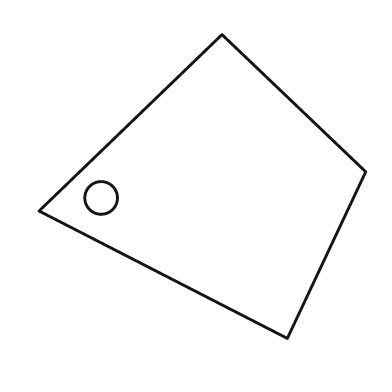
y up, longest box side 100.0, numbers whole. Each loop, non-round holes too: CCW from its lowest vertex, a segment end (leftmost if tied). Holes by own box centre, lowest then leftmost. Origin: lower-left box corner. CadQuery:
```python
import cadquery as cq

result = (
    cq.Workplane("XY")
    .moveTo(76.0, 0.0)
    .lineTo(100.0, 51.0)
    .lineTo(56.0, 93.0)
    .lineTo(0.0, 39.0)
    .close()
    .moveTo(19.0, 43.0)
    .circle(5.0)
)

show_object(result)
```